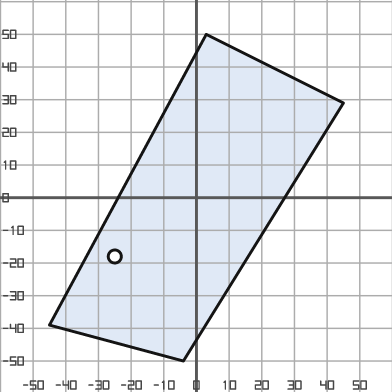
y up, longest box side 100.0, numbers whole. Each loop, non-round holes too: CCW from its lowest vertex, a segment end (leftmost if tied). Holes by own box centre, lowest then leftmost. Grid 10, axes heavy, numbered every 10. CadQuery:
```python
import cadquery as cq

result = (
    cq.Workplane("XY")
    .moveTo(-4.0, -50.0)
    .lineTo(45.0, 29.0)
    .lineTo(3.0, 50.0)
    .lineTo(-45.0, -39.0)
    .close()
    .moveTo(-25.0, -18.0)
    .circle(2.0)
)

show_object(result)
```